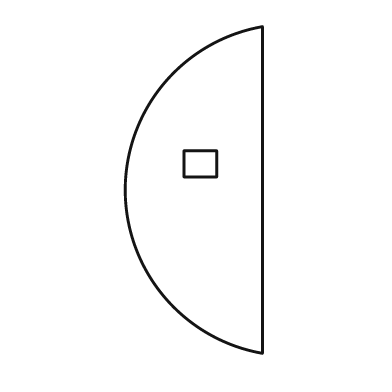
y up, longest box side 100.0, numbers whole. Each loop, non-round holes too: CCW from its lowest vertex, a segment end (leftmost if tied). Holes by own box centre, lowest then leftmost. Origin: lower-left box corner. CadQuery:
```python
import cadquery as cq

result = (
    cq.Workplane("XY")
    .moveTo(42.0, 0.0)
    .lineTo(42.0, 100.0)
    .threePointArc((0.0, 50.0), (42.0, 0.0))
    .close()
    .moveTo(18.0, 54.0)
    .lineTo(28.0, 54.0)
    .lineTo(28.0, 62.0)
    .lineTo(18.0, 62.0)
    .close()
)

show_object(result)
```